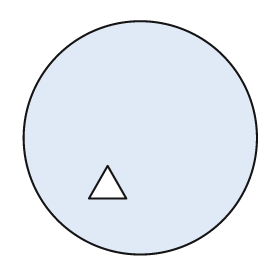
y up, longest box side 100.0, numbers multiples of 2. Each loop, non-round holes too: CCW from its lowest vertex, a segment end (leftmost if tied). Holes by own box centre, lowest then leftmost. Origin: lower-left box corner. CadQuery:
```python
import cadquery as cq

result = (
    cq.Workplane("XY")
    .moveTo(50.0, 50.0)
    .circle(50.0)
    .moveTo(28.0, 24.0)
    .lineTo(44.0, 24.0)
    .lineTo(36.0, 38.0)
    .close()
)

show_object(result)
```